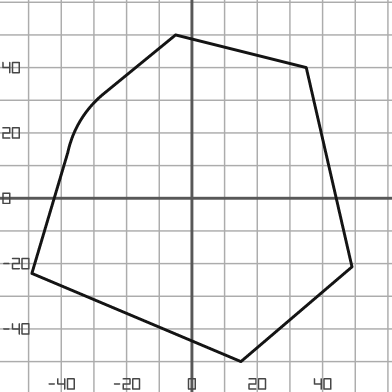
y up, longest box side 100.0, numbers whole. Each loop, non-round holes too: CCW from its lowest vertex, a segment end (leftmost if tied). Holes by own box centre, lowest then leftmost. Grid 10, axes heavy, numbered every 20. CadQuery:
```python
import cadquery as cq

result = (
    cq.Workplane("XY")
    .moveTo(15.0, -50.0)
    .lineTo(49.0, -21.0)
    .lineTo(35.0, 40.0)
    .lineTo(-5.0, 50.0)
    .lineTo(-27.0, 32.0)
    .threePointArc((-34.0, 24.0), (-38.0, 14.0))
    .lineTo(-49.0, -23.0)
    .close()
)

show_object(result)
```